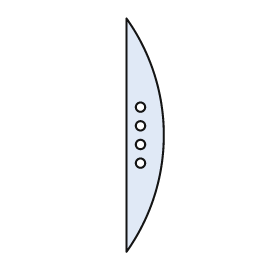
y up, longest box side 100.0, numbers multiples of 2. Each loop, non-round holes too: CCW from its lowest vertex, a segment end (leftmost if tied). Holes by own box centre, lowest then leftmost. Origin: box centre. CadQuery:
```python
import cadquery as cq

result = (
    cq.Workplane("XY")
    .moveTo(-8.0, -50.0)
    .threePointArc((8.0, 0.0), (-8.0, 50.0))
    .close()
    .moveTo(-2.0, -12.0)
    .circle(2.0)
    .moveTo(-2.0, -4.0)
    .circle(2.0)
    .moveTo(-2.0, 4.0)
    .circle(2.0)
    .moveTo(-2.0, 12.0)
    .circle(2.0)
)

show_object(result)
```